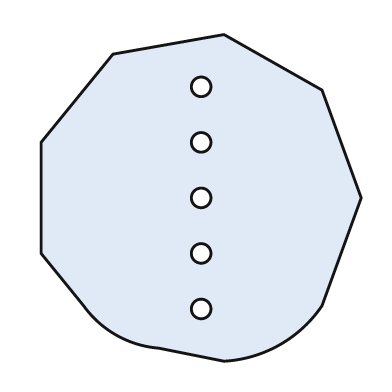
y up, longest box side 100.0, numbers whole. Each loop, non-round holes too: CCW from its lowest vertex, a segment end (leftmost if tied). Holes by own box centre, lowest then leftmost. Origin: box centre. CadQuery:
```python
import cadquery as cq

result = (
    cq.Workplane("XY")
    .moveTo(7.0, -50.0)
    .threePointArc((24.0, -45.0), (37.0, -33.0))
    .lineTo(49.0, 0.0)
    .lineTo(37.0, 33.0)
    .lineTo(7.0, 50.0)
    .lineTo(-27.0, 44.0)
    .lineTo(-49.0, 17.0)
    .lineTo(-49.0, -17.0)
    .lineTo(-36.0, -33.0)
    .threePointArc((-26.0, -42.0), (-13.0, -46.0))
    .close()
    .moveTo(0.0, -34.0)
    .circle(3.0)
    .moveTo(0.0, -17.0)
    .circle(3.0)
    .moveTo(0.0, 0.0)
    .circle(3.0)
    .moveTo(0.0, 17.0)
    .circle(3.0)
    .moveTo(0.0, 34.0)
    .circle(3.0)
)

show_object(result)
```